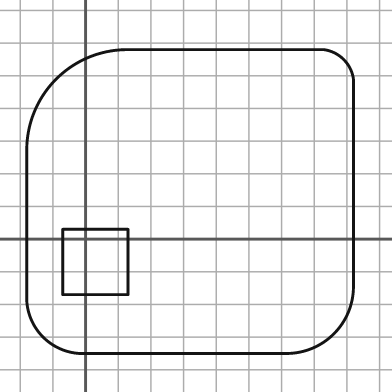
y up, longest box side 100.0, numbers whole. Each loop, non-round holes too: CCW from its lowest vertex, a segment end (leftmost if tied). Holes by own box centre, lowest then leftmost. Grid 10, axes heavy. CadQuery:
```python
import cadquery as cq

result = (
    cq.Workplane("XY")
    .moveTo(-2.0, -35.0)
    .lineTo(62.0, -35.0)
    .threePointArc((76.0, -29.0), (82.0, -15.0))
    .lineTo(82.0, 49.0)
    .threePointArc((79.0, 55.0), (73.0, 58.0))
    .lineTo(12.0, 58.0)
    .threePointArc((-9.0, 49.0), (-18.0, 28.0))
    .lineTo(-18.0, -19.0)
    .threePointArc((-13.0, -30.0), (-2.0, -35.0))
    .close()
    .moveTo(-7.0, -17.0)
    .lineTo(13.0, -17.0)
    .lineTo(13.0, 3.0)
    .lineTo(-7.0, 3.0)
    .close()
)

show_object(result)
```